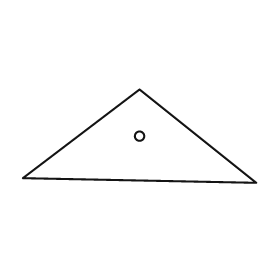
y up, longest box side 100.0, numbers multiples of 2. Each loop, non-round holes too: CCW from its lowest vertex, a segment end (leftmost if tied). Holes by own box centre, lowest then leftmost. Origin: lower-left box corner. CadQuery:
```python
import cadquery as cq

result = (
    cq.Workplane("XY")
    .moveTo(100.0, 0.0)
    .lineTo(50.0, 40.0)
    .lineTo(0.0, 2.0)
    .close()
    .moveTo(50.0, 20.0)
    .circle(2.0)
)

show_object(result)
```